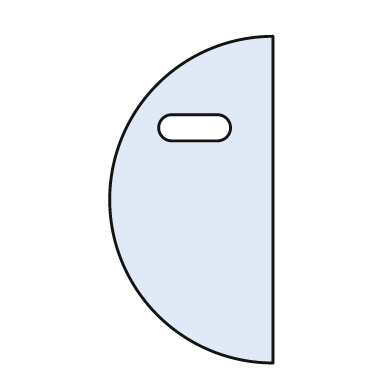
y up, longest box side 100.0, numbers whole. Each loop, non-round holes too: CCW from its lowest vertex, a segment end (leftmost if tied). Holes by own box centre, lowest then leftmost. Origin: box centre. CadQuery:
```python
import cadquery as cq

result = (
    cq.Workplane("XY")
    .moveTo(25.0, -50.0)
    .lineTo(25.0, 50.0)
    .threePointArc((-25.0, 0.0), (25.0, -50.0))
    .close()
    .moveTo(-6.0, 18.0)
    .lineTo(8.0, 18.0)
    .threePointArc((12.0, 22.0), (8.0, 26.0))
    .lineTo(-6.0, 26.0)
    .threePointArc((-10.0, 22.0), (-6.0, 18.0))
    .close()
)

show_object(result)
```